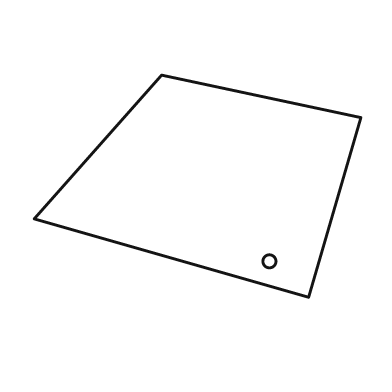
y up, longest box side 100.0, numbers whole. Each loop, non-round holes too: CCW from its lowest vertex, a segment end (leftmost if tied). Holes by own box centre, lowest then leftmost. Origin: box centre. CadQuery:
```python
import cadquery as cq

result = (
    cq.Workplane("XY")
    .moveTo(34.0, -34.0)
    .lineTo(50.0, 21.0)
    .lineTo(-11.0, 34.0)
    .lineTo(-50.0, -10.0)
    .close()
    .moveTo(22.0, -23.0)
    .circle(2.0)
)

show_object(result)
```